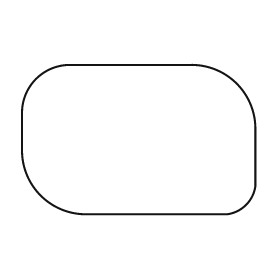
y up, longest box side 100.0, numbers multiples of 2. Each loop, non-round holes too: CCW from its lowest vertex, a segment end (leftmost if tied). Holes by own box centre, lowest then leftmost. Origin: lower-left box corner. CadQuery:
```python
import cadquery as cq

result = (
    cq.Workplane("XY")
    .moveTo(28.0, 0.0)
    .lineTo(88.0, 0.0)
    .threePointArc((96.0, 4.0), (100.0, 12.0))
    .lineTo(100.0, 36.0)
    .threePointArc((92.0, 56.0), (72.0, 64.0))
    .lineTo(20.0, 64.0)
    .threePointArc((6.0, 58.0), (0.0, 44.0))
    .lineTo(0.0, 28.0)
    .threePointArc((8.0, 8.0), (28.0, 0.0))
    .close()
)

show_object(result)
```